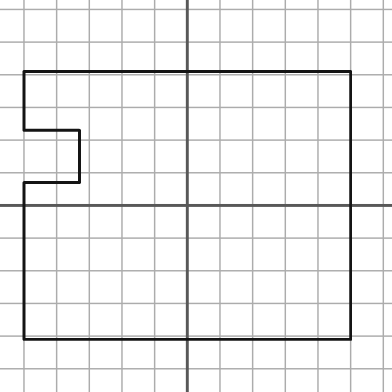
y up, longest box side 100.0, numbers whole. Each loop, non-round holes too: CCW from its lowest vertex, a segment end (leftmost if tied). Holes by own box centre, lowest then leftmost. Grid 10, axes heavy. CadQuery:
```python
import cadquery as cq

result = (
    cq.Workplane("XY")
    .moveTo(-50.0, -41.0)
    .lineTo(50.0, -41.0)
    .lineTo(50.0, 41.0)
    .lineTo(-50.0, 41.0)
    .lineTo(-50.0, 23.0)
    .lineTo(-33.0, 23.0)
    .lineTo(-33.0, 7.0)
    .lineTo(-50.0, 7.0)
    .close()
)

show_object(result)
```